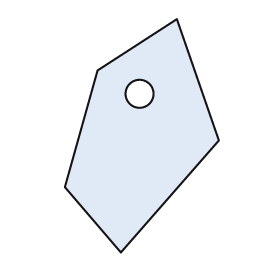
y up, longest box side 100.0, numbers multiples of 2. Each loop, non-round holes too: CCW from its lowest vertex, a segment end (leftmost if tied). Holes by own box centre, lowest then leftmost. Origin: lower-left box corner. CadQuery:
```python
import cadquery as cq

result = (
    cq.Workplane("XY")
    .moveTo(24.0, 0.0)
    .lineTo(66.0, 48.0)
    .lineTo(48.0, 100.0)
    .lineTo(14.0, 78.0)
    .lineTo(0.0, 28.0)
    .close()
    .moveTo(32.0, 68.0)
    .circle(6.0)
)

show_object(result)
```